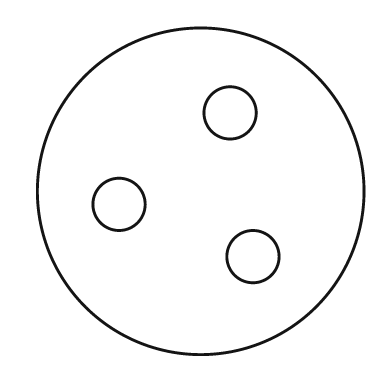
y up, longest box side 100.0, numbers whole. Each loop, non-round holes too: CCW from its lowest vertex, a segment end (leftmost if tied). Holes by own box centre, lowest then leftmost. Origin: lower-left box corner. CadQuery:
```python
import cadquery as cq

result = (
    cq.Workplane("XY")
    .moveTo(50.0, 50.0)
    .circle(50.0)
    .moveTo(66.0, 30.0)
    .circle(8.0)
    .moveTo(25.0, 46.0)
    .circle(8.0)
    .moveTo(59.0, 74.0)
    .circle(8.0)
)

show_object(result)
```